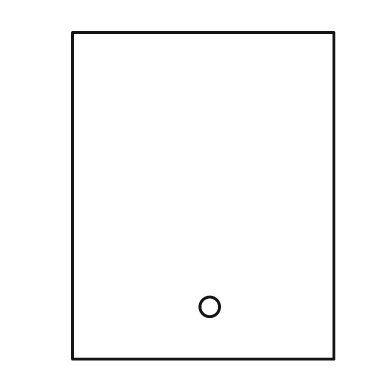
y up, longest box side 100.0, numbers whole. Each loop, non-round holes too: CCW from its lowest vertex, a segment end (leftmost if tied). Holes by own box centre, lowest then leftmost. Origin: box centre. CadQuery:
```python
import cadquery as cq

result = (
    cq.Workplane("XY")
    .moveTo(-40.0, -50.0)
    .lineTo(40.0, -50.0)
    .lineTo(40.0, 50.0)
    .lineTo(-40.0, 50.0)
    .close()
    .moveTo(2.0, -34.0)
    .circle(3.0)
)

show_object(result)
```